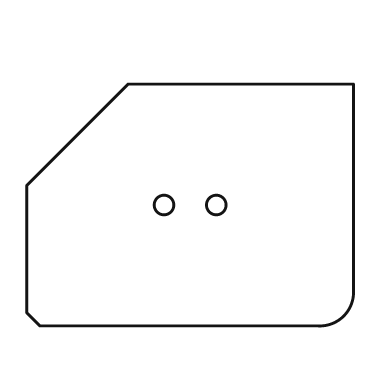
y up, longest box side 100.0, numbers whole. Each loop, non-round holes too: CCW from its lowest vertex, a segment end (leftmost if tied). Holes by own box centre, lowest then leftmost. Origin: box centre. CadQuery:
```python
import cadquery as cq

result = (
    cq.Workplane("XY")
    .moveTo(-46.0, -37.0)
    .lineTo(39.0, -37.0)
    .threePointArc((47.0, -34.0), (50.0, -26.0))
    .lineTo(50.0, 37.0)
    .lineTo(-19.0, 37.0)
    .lineTo(-50.0, 6.0)
    .lineTo(-50.0, -33.0)
    .close()
    .moveTo(-8.0, 0.0)
    .circle(3.0)
    .moveTo(8.0, 0.0)
    .circle(3.0)
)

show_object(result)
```